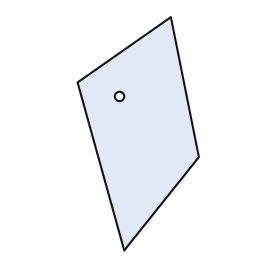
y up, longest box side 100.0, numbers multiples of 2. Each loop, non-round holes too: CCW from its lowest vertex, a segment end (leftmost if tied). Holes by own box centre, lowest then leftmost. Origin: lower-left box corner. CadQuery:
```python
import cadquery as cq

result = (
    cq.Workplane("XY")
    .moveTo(20.0, 0.0)
    .lineTo(52.0, 40.0)
    .lineTo(40.0, 100.0)
    .lineTo(0.0, 72.0)
    .close()
    .moveTo(18.0, 66.0)
    .circle(2.0)
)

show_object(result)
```